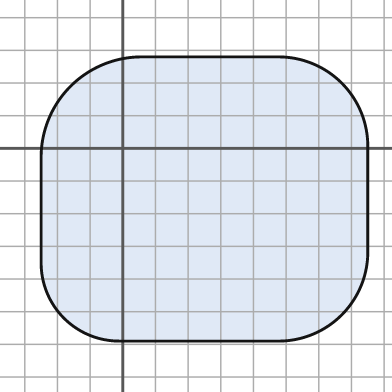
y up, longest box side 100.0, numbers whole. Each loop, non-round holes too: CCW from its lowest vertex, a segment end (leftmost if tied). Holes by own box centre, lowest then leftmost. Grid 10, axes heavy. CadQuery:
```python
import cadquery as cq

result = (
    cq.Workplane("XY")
    .moveTo(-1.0, -59.0)
    .lineTo(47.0, -59.0)
    .threePointArc((67.0, -51.0), (75.0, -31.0))
    .lineTo(75.0, 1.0)
    .threePointArc((67.0, 20.0), (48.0, 28.0))
    .lineTo(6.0, 28.0)
    .threePointArc((-16.0, 19.0), (-25.0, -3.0))
    .lineTo(-25.0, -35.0)
    .threePointArc((-18.0, -52.0), (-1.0, -59.0))
    .close()
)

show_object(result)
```